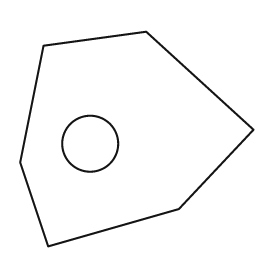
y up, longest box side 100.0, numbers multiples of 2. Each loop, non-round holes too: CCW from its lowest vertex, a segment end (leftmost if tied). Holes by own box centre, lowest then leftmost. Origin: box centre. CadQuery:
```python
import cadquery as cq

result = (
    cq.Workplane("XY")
    .moveTo(-38.0, -46.0)
    .lineTo(18.0, -30.0)
    .lineTo(50.0, 4.0)
    .lineTo(4.0, 46.0)
    .lineTo(-40.0, 40.0)
    .lineTo(-50.0, -10.0)
    .close()
    .moveTo(-20.0, -2.0)
    .circle(12.0)
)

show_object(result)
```